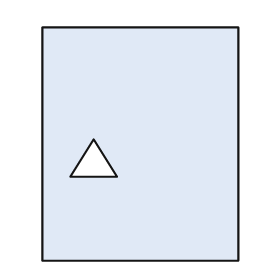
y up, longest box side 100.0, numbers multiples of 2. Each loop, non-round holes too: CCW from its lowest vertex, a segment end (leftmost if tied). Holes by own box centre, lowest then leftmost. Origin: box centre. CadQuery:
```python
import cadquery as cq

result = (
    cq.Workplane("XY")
    .moveTo(-42.0, -50.0)
    .lineTo(42.0, -50.0)
    .lineTo(42.0, 50.0)
    .lineTo(-42.0, 50.0)
    .close()
    .moveTo(-30.0, -14.0)
    .lineTo(-10.0, -14.0)
    .lineTo(-20.0, 2.0)
    .close()
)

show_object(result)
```